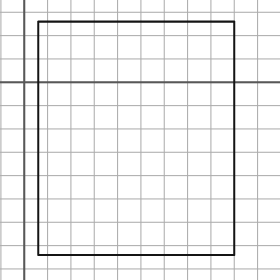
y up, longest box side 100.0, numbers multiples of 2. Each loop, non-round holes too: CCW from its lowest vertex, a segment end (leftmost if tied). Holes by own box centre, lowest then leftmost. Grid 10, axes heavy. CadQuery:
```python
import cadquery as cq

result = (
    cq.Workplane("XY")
    .moveTo(6.0, -74.0)
    .lineTo(90.0, -74.0)
    .lineTo(90.0, 26.0)
    .lineTo(6.0, 26.0)
    .close()
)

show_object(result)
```